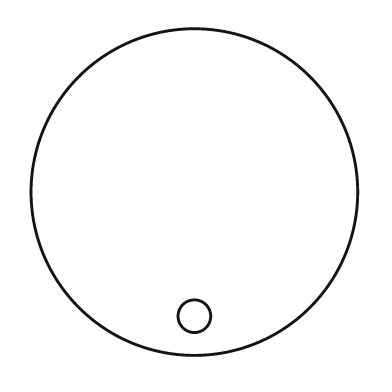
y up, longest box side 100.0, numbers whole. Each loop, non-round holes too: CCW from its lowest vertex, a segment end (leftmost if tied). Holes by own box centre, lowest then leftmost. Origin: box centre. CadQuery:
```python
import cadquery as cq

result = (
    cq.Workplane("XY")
    .moveTo(0.0, 0.0)
    .circle(50.0)
    .moveTo(0.0, -38.0)
    .circle(5.0)
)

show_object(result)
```